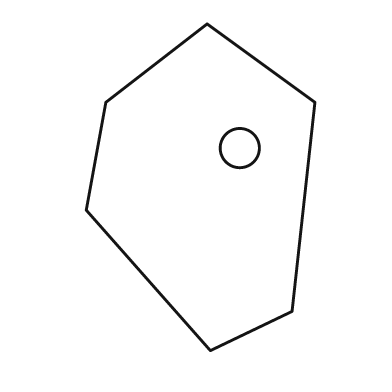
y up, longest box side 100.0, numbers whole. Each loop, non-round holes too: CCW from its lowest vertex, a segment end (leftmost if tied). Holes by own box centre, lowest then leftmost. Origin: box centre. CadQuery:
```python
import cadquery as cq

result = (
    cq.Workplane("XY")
    .moveTo(3.0, -50.0)
    .lineTo(28.0, -38.0)
    .lineTo(35.0, 26.0)
    .lineTo(2.0, 50.0)
    .lineTo(-29.0, 26.0)
    .lineTo(-35.0, -7.0)
    .close()
    .moveTo(12.0, 12.0)
    .circle(6.0)
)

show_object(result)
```